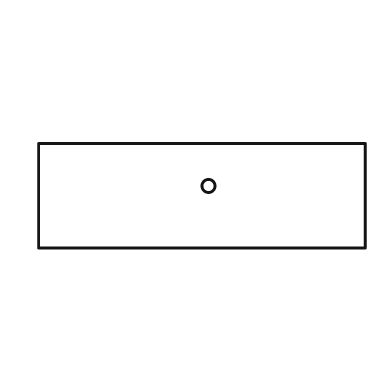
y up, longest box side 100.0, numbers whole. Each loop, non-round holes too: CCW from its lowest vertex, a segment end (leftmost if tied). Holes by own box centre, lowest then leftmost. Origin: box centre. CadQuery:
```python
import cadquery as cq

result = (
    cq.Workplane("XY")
    .moveTo(-50.0, -16.0)
    .lineTo(50.0, -16.0)
    .lineTo(50.0, 16.0)
    .lineTo(-50.0, 16.0)
    .close()
    .moveTo(2.0, 3.0)
    .circle(2.0)
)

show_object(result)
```